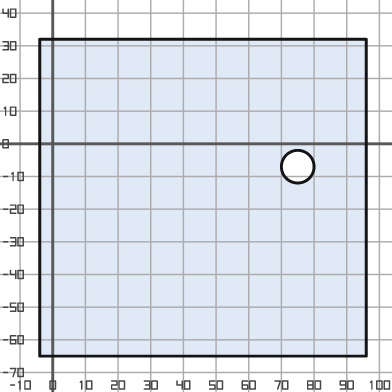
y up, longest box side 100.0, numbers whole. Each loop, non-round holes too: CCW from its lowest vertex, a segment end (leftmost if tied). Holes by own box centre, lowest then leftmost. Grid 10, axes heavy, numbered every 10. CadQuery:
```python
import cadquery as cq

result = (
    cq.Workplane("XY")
    .moveTo(-4.0, -65.0)
    .lineTo(96.0, -65.0)
    .lineTo(96.0, 32.0)
    .lineTo(-4.0, 32.0)
    .close()
    .moveTo(75.0, -7.0)
    .circle(5.0)
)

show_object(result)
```